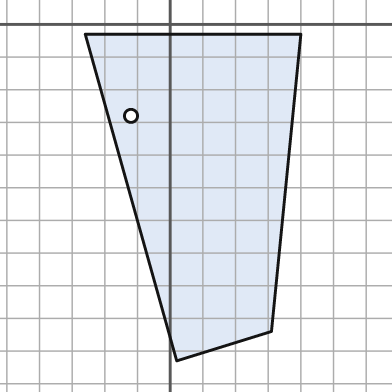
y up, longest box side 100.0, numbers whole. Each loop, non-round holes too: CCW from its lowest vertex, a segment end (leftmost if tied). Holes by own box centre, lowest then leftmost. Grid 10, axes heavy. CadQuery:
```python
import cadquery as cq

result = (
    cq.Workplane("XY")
    .moveTo(2.0, -103.0)
    .lineTo(31.0, -94.0)
    .lineTo(40.0, -3.0)
    .lineTo(-26.0, -3.0)
    .close()
    .moveTo(-12.0, -28.0)
    .circle(2.0)
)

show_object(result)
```